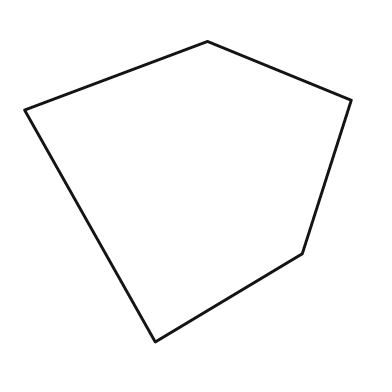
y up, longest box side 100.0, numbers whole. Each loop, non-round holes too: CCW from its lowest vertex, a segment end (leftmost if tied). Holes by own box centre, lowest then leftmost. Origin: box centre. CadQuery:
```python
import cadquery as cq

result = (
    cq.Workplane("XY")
    .moveTo(-10.0, -46.0)
    .lineTo(35.0, -19.0)
    .lineTo(50.0, 28.0)
    .lineTo(6.0, 46.0)
    .lineTo(-50.0, 25.0)
    .close()
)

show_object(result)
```